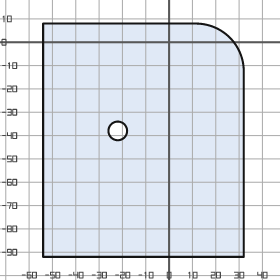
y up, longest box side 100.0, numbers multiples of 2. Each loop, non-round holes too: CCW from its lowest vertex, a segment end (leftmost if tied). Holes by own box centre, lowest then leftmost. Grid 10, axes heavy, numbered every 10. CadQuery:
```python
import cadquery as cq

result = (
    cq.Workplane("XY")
    .moveTo(-54.0, -92.0)
    .lineTo(32.0, -92.0)
    .lineTo(32.0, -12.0)
    .threePointArc((26.0, 2.0), (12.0, 8.0))
    .lineTo(-54.0, 8.0)
    .close()
    .moveTo(-22.0, -38.0)
    .circle(4.0)
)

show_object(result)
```